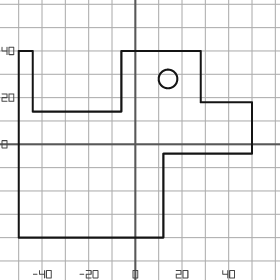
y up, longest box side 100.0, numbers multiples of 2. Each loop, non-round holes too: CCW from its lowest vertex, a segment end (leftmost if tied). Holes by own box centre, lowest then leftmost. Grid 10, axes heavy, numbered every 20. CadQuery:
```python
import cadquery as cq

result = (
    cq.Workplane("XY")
    .moveTo(-50.0, -40.0)
    .lineTo(12.0, -40.0)
    .lineTo(12.0, -4.0)
    .lineTo(50.0, -4.0)
    .lineTo(50.0, 18.0)
    .lineTo(28.0, 18.0)
    .lineTo(28.0, 40.0)
    .lineTo(-6.0, 40.0)
    .lineTo(-6.0, 14.0)
    .lineTo(-44.0, 14.0)
    .lineTo(-44.0, 40.0)
    .lineTo(-50.0, 40.0)
    .close()
    .moveTo(14.0, 28.0)
    .circle(4.0)
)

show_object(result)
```